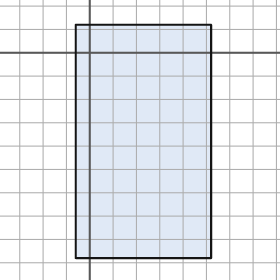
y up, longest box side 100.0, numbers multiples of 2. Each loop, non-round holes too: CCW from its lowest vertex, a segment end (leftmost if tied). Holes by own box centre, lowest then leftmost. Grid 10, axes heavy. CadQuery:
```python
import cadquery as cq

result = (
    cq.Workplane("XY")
    .moveTo(-6.0, -88.0)
    .lineTo(52.0, -88.0)
    .lineTo(52.0, 12.0)
    .lineTo(-6.0, 12.0)
    .close()
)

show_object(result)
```